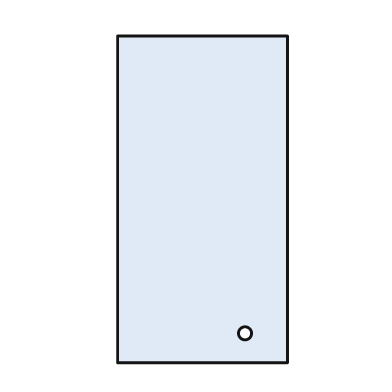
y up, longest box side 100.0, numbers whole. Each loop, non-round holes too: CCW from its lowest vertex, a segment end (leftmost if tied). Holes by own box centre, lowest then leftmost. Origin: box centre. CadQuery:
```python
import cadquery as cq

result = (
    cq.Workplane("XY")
    .moveTo(-26.0, -50.0)
    .lineTo(26.0, -50.0)
    .lineTo(26.0, 50.0)
    .lineTo(-26.0, 50.0)
    .close()
    .moveTo(13.0, -41.0)
    .circle(2.0)
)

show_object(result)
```